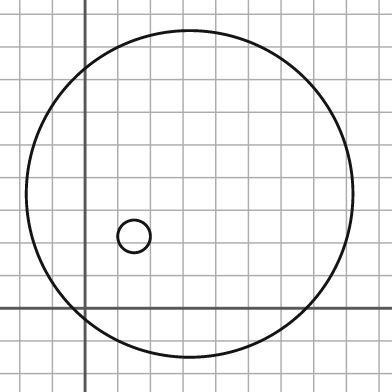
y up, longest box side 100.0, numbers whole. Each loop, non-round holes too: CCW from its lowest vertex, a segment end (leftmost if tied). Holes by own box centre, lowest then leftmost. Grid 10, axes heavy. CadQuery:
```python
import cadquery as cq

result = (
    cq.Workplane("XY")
    .moveTo(32.0, 35.0)
    .circle(50.0)
    .moveTo(15.0, 22.0)
    .circle(5.0)
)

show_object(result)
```